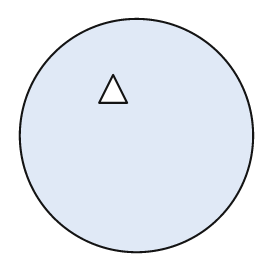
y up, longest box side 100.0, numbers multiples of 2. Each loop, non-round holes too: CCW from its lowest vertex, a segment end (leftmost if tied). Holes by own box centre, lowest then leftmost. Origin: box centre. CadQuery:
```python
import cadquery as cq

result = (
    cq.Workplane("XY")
    .moveTo(0.0, 0.0)
    .circle(50.0)
    .moveTo(-16.0, 14.0)
    .lineTo(-4.0, 14.0)
    .lineTo(-10.0, 26.0)
    .close()
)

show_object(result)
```